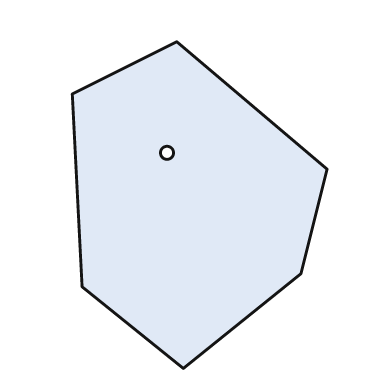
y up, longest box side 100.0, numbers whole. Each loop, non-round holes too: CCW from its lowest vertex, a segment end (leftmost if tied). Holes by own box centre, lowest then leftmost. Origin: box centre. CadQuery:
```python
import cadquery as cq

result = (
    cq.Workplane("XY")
    .moveTo(-5.0, -50.0)
    .lineTo(31.0, -21.0)
    .lineTo(39.0, 11.0)
    .lineTo(-7.0, 50.0)
    .lineTo(-39.0, 34.0)
    .lineTo(-36.0, -25.0)
    .close()
    .moveTo(-10.0, 16.0)
    .circle(2.0)
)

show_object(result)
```